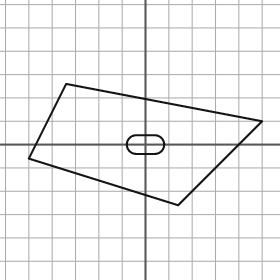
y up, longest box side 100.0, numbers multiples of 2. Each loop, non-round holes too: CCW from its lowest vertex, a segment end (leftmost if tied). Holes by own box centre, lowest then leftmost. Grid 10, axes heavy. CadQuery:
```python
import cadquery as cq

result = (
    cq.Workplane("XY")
    .moveTo(14.0, -26.0)
    .lineTo(50.0, 10.0)
    .lineTo(-34.0, 26.0)
    .lineTo(-50.0, -6.0)
    .close()
    .moveTo(-4.0, -4.0)
    .lineTo(4.0, -4.0)
    .threePointArc((8.0, 0.0), (4.0, 4.0))
    .lineTo(-4.0, 4.0)
    .threePointArc((-8.0, 0.0), (-4.0, -4.0))
    .close()
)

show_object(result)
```